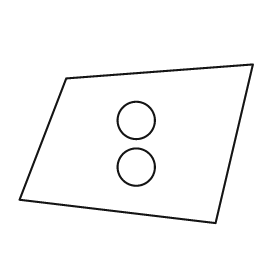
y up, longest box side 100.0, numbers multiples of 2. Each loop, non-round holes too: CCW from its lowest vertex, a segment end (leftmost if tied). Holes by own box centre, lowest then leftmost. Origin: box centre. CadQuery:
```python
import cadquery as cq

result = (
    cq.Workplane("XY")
    .moveTo(34.0, -34.0)
    .lineTo(50.0, 34.0)
    .lineTo(-30.0, 28.0)
    .lineTo(-50.0, -24.0)
    .close()
    .moveTo(0.0, -10.0)
    .circle(8.0)
    .moveTo(0.0, 10.0)
    .circle(8.0)
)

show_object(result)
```